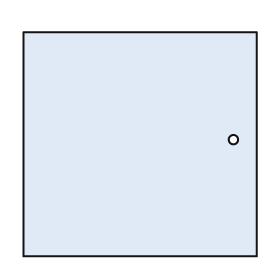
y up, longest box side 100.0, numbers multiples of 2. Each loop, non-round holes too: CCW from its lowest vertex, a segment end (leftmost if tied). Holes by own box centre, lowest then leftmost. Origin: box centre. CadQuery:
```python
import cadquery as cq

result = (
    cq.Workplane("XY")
    .moveTo(-50.0, -48.0)
    .lineTo(50.0, -48.0)
    .lineTo(50.0, 48.0)
    .lineTo(-50.0, 48.0)
    .close()
    .moveTo(40.0, 2.0)
    .circle(2.0)
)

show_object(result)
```